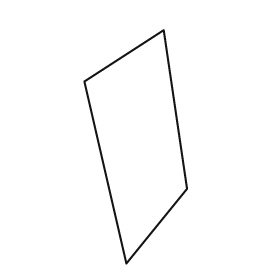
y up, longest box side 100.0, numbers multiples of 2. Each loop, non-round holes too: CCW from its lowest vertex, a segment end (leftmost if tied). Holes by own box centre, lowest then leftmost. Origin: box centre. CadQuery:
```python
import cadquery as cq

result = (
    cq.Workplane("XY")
    .moveTo(-4.0, -50.0)
    .lineTo(22.0, -18.0)
    .lineTo(12.0, 50.0)
    .lineTo(-22.0, 28.0)
    .close()
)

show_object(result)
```